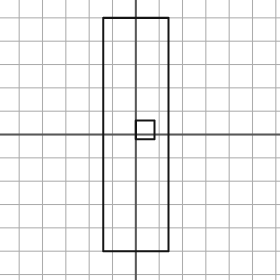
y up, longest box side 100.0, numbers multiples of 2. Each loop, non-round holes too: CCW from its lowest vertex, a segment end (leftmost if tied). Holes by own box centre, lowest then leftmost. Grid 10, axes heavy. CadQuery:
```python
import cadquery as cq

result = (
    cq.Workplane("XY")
    .moveTo(-14.0, -50.0)
    .lineTo(14.0, -50.0)
    .lineTo(14.0, 50.0)
    .lineTo(-14.0, 50.0)
    .close()
    .moveTo(0.0, -2.0)
    .lineTo(8.0, -2.0)
    .lineTo(8.0, 6.0)
    .lineTo(0.0, 6.0)
    .close()
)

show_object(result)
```